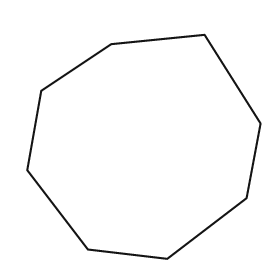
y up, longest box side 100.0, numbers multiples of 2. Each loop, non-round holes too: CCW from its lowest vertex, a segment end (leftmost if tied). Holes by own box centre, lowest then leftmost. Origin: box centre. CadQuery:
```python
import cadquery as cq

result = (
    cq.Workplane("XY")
    .moveTo(10.0, -48.0)
    .lineTo(44.0, -22.0)
    .lineTo(50.0, 10.0)
    .lineTo(26.0, 48.0)
    .lineTo(-14.0, 44.0)
    .lineTo(-44.0, 24.0)
    .lineTo(-50.0, -10.0)
    .lineTo(-24.0, -44.0)
    .close()
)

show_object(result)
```